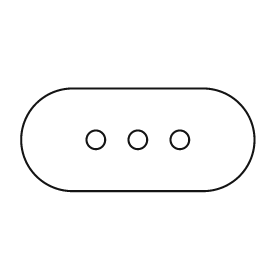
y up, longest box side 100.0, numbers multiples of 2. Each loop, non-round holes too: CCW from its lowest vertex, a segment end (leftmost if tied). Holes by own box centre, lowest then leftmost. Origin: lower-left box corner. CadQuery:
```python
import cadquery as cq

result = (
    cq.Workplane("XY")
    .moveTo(22.0, 0.0)
    .lineTo(78.0, 0.0)
    .threePointArc((100.0, 22.0), (78.0, 44.0))
    .lineTo(22.0, 44.0)
    .threePointArc((0.0, 22.0), (22.0, 0.0))
    .close()
    .moveTo(32.0, 22.0)
    .circle(4.0)
    .moveTo(50.0, 22.0)
    .circle(4.0)
    .moveTo(68.0, 22.0)
    .circle(4.0)
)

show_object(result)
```